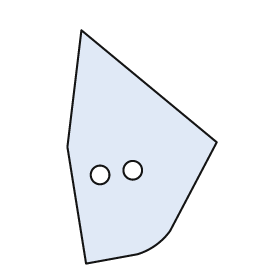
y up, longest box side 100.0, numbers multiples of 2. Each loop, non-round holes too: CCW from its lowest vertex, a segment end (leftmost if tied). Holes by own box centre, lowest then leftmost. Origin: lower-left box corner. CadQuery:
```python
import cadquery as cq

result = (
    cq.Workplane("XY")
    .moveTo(8.0, 0.0)
    .lineTo(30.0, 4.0)
    .threePointArc((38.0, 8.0), (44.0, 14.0))
    .lineTo(64.0, 52.0)
    .lineTo(6.0, 100.0)
    .lineTo(0.0, 50.0)
    .close()
    .moveTo(14.0, 38.0)
    .circle(4.0)
    .moveTo(28.0, 40.0)
    .circle(4.0)
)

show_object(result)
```